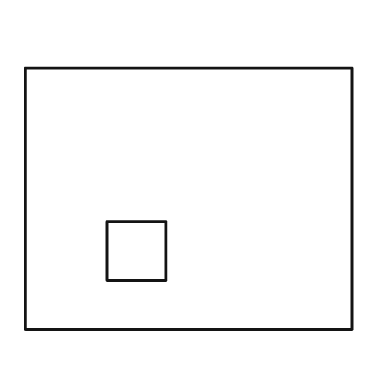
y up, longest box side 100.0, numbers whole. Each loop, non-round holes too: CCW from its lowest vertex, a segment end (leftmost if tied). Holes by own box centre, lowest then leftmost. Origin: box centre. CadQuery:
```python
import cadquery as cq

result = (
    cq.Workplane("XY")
    .moveTo(-50.0, -40.0)
    .lineTo(50.0, -40.0)
    .lineTo(50.0, 40.0)
    .lineTo(-50.0, 40.0)
    .close()
    .moveTo(-25.0, -25.0)
    .lineTo(-7.0, -25.0)
    .lineTo(-7.0, -7.0)
    .lineTo(-25.0, -7.0)
    .close()
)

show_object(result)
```